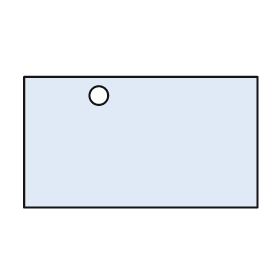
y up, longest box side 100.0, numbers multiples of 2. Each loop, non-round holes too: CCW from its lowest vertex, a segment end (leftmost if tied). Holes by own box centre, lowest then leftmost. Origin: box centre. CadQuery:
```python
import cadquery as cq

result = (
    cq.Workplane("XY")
    .moveTo(-50.0, -28.0)
    .lineTo(50.0, -28.0)
    .lineTo(50.0, 28.0)
    .lineTo(-50.0, 28.0)
    .close()
    .moveTo(-18.0, 20.0)
    .circle(4.0)
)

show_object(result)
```